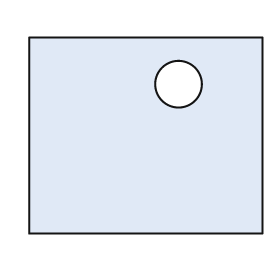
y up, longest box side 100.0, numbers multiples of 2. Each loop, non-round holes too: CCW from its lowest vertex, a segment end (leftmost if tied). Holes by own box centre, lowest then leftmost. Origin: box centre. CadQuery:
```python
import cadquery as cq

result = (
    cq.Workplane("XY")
    .moveTo(-50.0, -42.0)
    .lineTo(50.0, -42.0)
    .lineTo(50.0, 42.0)
    .lineTo(-50.0, 42.0)
    .close()
    .moveTo(14.0, 22.0)
    .circle(10.0)
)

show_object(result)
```